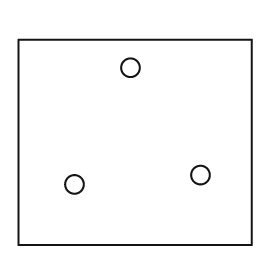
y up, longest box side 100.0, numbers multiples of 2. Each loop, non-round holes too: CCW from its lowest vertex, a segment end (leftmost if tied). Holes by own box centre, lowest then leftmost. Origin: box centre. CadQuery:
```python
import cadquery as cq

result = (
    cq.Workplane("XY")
    .moveTo(-50.0, -44.0)
    .lineTo(50.0, -44.0)
    .lineTo(50.0, 44.0)
    .lineTo(-50.0, 44.0)
    .close()
    .moveTo(-26.0, -18.0)
    .circle(4.0)
    .moveTo(28.0, -14.0)
    .circle(4.0)
    .moveTo(-2.0, 32.0)
    .circle(4.0)
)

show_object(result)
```